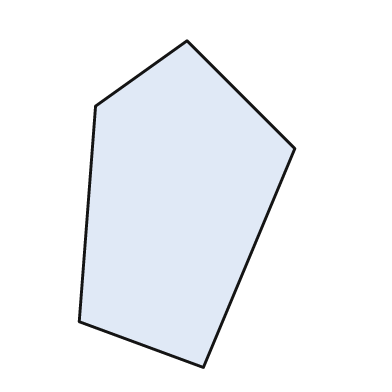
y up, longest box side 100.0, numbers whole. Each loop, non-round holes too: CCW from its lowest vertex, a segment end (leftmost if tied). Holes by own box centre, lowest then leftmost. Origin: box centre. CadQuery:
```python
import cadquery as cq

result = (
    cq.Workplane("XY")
    .moveTo(5.0, -50.0)
    .lineTo(33.0, 17.0)
    .lineTo(0.0, 50.0)
    .lineTo(-28.0, 30.0)
    .lineTo(-33.0, -36.0)
    .close()
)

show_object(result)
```